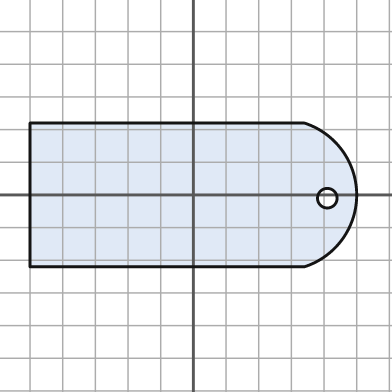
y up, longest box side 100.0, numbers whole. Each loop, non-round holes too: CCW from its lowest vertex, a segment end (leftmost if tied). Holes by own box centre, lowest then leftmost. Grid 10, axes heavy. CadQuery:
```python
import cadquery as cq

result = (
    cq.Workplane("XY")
    .moveTo(-50.0, -22.0)
    .lineTo(34.0, -22.0)
    .threePointArc((50.0, 0.0), (34.0, 22.0))
    .lineTo(-50.0, 22.0)
    .close()
    .moveTo(41.0, -1.0)
    .circle(3.0)
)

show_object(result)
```